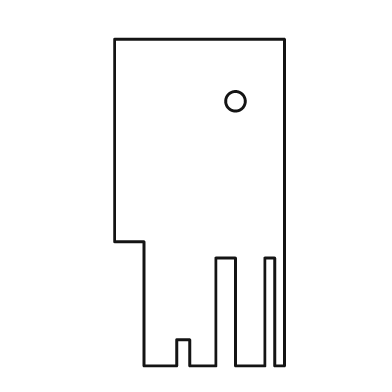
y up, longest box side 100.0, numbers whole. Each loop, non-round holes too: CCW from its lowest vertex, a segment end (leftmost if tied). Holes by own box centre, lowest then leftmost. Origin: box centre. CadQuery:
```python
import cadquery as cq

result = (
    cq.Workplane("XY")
    .moveTo(-17.0, -50.0)
    .lineTo(-7.0, -50.0)
    .lineTo(-7.0, -42.0)
    .lineTo(-3.0, -42.0)
    .lineTo(-3.0, -50.0)
    .lineTo(5.0, -50.0)
    .lineTo(5.0, -17.0)
    .lineTo(11.0, -17.0)
    .lineTo(11.0, -50.0)
    .lineTo(20.0, -50.0)
    .lineTo(20.0, -17.0)
    .lineTo(23.0, -17.0)
    .lineTo(23.0, -50.0)
    .lineTo(26.0, -50.0)
    .lineTo(26.0, 50.0)
    .lineTo(-26.0, 50.0)
    .lineTo(-26.0, -12.0)
    .lineTo(-17.0, -12.0)
    .close()
    .moveTo(11.0, 31.0)
    .circle(3.0)
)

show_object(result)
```